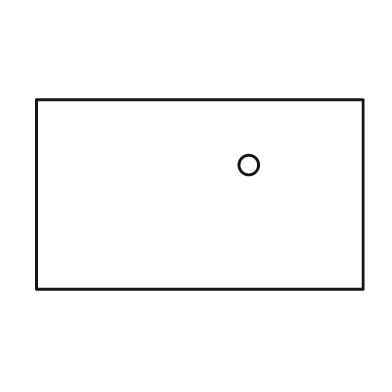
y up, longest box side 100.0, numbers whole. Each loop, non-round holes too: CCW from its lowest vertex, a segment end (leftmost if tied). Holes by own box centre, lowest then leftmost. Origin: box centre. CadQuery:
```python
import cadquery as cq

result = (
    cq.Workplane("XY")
    .moveTo(-50.0, -29.0)
    .lineTo(50.0, -29.0)
    .lineTo(50.0, 29.0)
    .lineTo(-50.0, 29.0)
    .close()
    .moveTo(15.0, 9.0)
    .circle(3.0)
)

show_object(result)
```